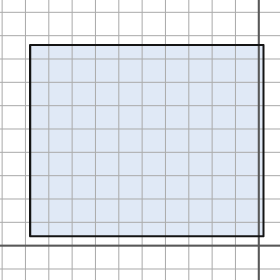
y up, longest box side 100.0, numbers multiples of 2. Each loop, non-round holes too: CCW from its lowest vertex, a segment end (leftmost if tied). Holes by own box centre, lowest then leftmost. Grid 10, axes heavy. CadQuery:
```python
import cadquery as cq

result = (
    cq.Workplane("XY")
    .moveTo(-98.0, 4.0)
    .lineTo(2.0, 4.0)
    .lineTo(2.0, 86.0)
    .lineTo(-98.0, 86.0)
    .close()
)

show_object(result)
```